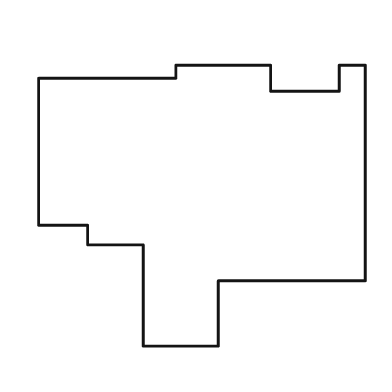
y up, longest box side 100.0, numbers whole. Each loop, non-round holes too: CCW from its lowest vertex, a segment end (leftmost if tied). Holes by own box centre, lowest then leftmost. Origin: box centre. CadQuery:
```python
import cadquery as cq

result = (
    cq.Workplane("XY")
    .moveTo(-18.0, -43.0)
    .lineTo(5.0, -43.0)
    .lineTo(5.0, -23.0)
    .lineTo(50.0, -23.0)
    .lineTo(50.0, 43.0)
    .lineTo(42.0, 43.0)
    .lineTo(42.0, 35.0)
    .lineTo(21.0, 35.0)
    .lineTo(21.0, 43.0)
    .lineTo(-8.0, 43.0)
    .lineTo(-8.0, 39.0)
    .lineTo(-50.0, 39.0)
    .lineTo(-50.0, -6.0)
    .lineTo(-35.0, -6.0)
    .lineTo(-35.0, -12.0)
    .lineTo(-18.0, -12.0)
    .close()
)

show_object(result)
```